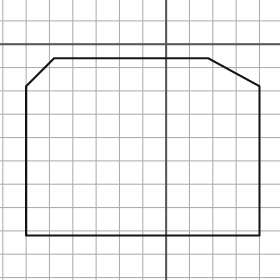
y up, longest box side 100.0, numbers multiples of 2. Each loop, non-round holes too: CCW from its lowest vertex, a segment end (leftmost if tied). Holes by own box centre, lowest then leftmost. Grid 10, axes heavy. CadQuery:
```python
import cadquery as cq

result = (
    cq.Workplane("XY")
    .moveTo(-60.0, -82.0)
    .lineTo(40.0, -82.0)
    .lineTo(40.0, -18.0)
    .lineTo(18.0, -6.0)
    .lineTo(-48.0, -6.0)
    .lineTo(-60.0, -18.0)
    .close()
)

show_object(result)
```